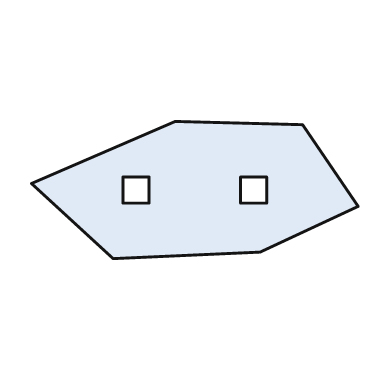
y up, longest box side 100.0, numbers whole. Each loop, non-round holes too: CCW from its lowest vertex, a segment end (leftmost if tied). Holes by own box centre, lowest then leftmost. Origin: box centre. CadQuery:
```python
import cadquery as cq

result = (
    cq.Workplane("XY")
    .moveTo(-25.0, -21.0)
    .lineTo(20.0, -19.0)
    .lineTo(50.0, -5.0)
    .lineTo(33.0, 20.0)
    .lineTo(-6.0, 21.0)
    .lineTo(-50.0, 2.0)
    .close()
    .moveTo(-22.0, -4.0)
    .lineTo(-14.0, -4.0)
    .lineTo(-14.0, 4.0)
    .lineTo(-22.0, 4.0)
    .close()
    .moveTo(14.0, -4.0)
    .lineTo(22.0, -4.0)
    .lineTo(22.0, 4.0)
    .lineTo(14.0, 4.0)
    .close()
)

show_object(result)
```